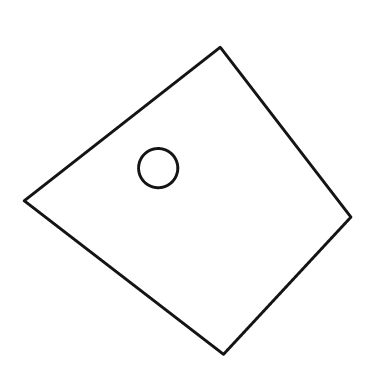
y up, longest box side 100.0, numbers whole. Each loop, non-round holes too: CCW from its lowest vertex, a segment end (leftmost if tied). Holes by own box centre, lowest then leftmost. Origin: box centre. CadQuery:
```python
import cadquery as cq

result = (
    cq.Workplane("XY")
    .moveTo(11.0, -47.0)
    .lineTo(50.0, -5.0)
    .lineTo(10.0, 47.0)
    .lineTo(-50.0, 0.0)
    .close()
    .moveTo(-9.0, 10.0)
    .circle(6.0)
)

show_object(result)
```